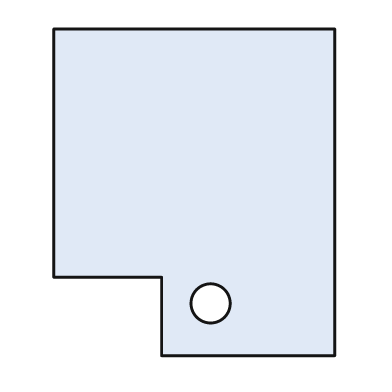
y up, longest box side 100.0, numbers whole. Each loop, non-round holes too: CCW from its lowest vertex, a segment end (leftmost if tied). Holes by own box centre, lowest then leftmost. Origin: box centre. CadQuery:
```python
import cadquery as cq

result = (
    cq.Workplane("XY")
    .moveTo(-10.0, -50.0)
    .lineTo(43.0, -50.0)
    .lineTo(43.0, 50.0)
    .lineTo(-43.0, 50.0)
    .lineTo(-43.0, -26.0)
    .lineTo(-10.0, -26.0)
    .close()
    .moveTo(5.0, -34.0)
    .circle(6.0)
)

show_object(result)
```